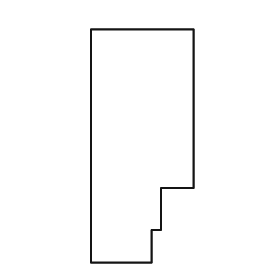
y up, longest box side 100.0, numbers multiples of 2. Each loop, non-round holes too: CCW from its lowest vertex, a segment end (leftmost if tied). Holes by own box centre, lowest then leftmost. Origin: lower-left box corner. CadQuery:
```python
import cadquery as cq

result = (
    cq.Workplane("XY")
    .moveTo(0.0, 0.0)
    .lineTo(26.0, 0.0)
    .lineTo(26.0, 14.0)
    .lineTo(30.0, 14.0)
    .lineTo(30.0, 32.0)
    .lineTo(44.0, 32.0)
    .lineTo(44.0, 100.0)
    .lineTo(0.0, 100.0)
    .close()
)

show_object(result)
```